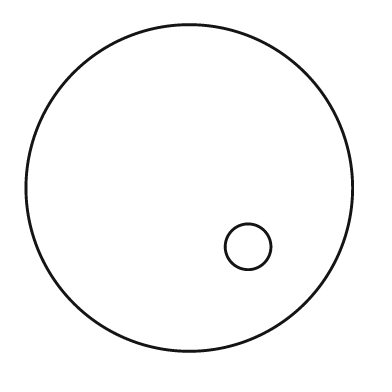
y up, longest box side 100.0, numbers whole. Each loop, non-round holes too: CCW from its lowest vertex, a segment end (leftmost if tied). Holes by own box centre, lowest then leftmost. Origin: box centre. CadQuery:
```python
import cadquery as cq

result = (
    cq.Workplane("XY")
    .moveTo(0.0, 0.0)
    .circle(50.0)
    .moveTo(18.0, -18.0)
    .circle(7.0)
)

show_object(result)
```